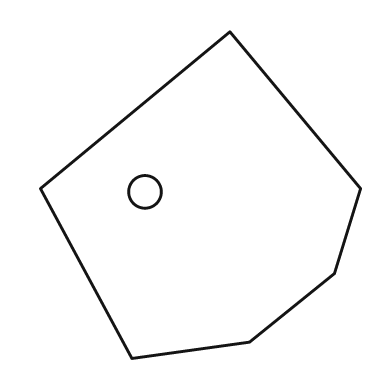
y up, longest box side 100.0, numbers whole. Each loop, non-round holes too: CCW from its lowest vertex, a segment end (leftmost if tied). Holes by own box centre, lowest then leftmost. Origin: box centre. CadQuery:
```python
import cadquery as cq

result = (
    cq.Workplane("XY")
    .moveTo(-21.0, -50.0)
    .lineTo(15.0, -45.0)
    .lineTo(41.0, -24.0)
    .lineTo(49.0, 2.0)
    .lineTo(9.0, 50.0)
    .lineTo(-49.0, 2.0)
    .close()
    .moveTo(-17.0, 1.0)
    .circle(5.0)
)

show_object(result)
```